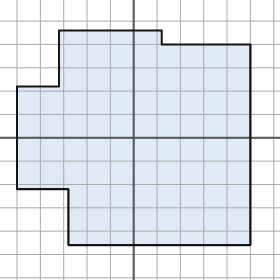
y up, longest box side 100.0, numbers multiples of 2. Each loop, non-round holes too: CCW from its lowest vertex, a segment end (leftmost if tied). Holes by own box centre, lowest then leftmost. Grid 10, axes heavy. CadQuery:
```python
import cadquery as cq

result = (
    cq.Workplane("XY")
    .moveTo(-28.0, -46.0)
    .lineTo(50.0, -46.0)
    .lineTo(50.0, 40.0)
    .lineTo(12.0, 40.0)
    .lineTo(12.0, 46.0)
    .lineTo(-32.0, 46.0)
    .lineTo(-32.0, 22.0)
    .lineTo(-50.0, 22.0)
    .lineTo(-50.0, -22.0)
    .lineTo(-28.0, -22.0)
    .close()
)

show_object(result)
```